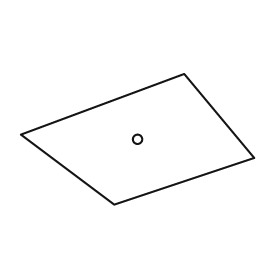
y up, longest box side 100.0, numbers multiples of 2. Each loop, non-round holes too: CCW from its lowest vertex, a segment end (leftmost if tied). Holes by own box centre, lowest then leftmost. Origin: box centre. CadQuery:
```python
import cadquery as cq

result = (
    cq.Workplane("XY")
    .moveTo(-10.0, -28.0)
    .lineTo(50.0, -8.0)
    .lineTo(20.0, 28.0)
    .lineTo(-50.0, 2.0)
    .close()
    .moveTo(0.0, 0.0)
    .circle(2.0)
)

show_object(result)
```